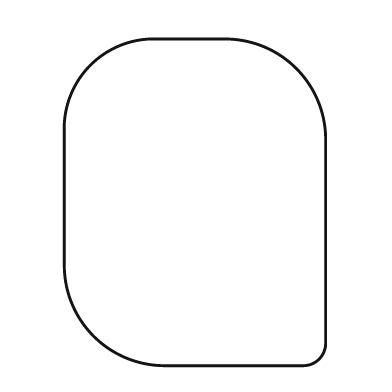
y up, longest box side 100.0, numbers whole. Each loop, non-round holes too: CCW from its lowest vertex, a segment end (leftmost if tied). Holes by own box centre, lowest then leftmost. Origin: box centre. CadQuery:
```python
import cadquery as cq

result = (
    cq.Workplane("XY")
    .moveTo(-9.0, -50.0)
    .lineTo(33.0, -50.0)
    .threePointArc((38.0, -48.0), (40.0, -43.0))
    .lineTo(40.0, 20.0)
    .threePointArc((31.0, 41.0), (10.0, 50.0))
    .lineTo(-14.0, 50.0)
    .threePointArc((-32.0, 42.0), (-40.0, 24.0))
    .lineTo(-40.0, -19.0)
    .threePointArc((-31.0, -41.0), (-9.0, -50.0))
    .close()
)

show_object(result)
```